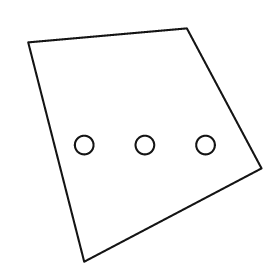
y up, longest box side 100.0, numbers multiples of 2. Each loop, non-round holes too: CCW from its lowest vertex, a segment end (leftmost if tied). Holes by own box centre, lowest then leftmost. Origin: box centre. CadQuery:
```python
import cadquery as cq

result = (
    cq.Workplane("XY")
    .moveTo(-26.0, -50.0)
    .lineTo(50.0, -10.0)
    .lineTo(18.0, 50.0)
    .lineTo(-50.0, 44.0)
    .close()
    .moveTo(-26.0, 0.0)
    .circle(4.0)
    .moveTo(0.0, 0.0)
    .circle(4.0)
    .moveTo(26.0, 0.0)
    .circle(4.0)
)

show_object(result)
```